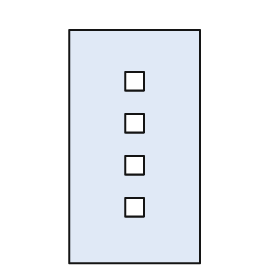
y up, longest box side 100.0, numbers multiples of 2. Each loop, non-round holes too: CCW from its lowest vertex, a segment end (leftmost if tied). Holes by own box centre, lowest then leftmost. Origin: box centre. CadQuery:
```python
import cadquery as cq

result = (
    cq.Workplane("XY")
    .moveTo(-28.0, -50.0)
    .lineTo(28.0, -50.0)
    .lineTo(28.0, 50.0)
    .lineTo(-28.0, 50.0)
    .close()
    .moveTo(-4.0, -30.0)
    .lineTo(4.0, -30.0)
    .lineTo(4.0, -22.0)
    .lineTo(-4.0, -22.0)
    .close()
    .moveTo(-4.0, -12.0)
    .lineTo(4.0, -12.0)
    .lineTo(4.0, -4.0)
    .lineTo(-4.0, -4.0)
    .close()
    .moveTo(-4.0, 6.0)
    .lineTo(4.0, 6.0)
    .lineTo(4.0, 14.0)
    .lineTo(-4.0, 14.0)
    .close()
    .moveTo(-4.0, 24.0)
    .lineTo(4.0, 24.0)
    .lineTo(4.0, 32.0)
    .lineTo(-4.0, 32.0)
    .close()
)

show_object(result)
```